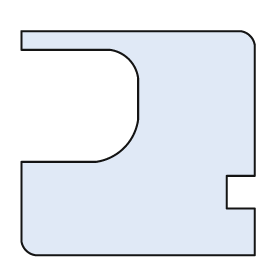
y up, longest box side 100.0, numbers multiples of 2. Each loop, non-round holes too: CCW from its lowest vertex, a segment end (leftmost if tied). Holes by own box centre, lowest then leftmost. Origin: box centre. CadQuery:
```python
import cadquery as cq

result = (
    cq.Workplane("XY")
    .moveTo(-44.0, -48.0)
    .lineTo(50.0, -48.0)
    .lineTo(50.0, -28.0)
    .lineTo(38.0, -28.0)
    .lineTo(38.0, -14.0)
    .lineTo(50.0, -14.0)
    .lineTo(50.0, 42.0)
    .threePointArc((48.0, 46.0), (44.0, 48.0))
    .lineTo(-50.0, 48.0)
    .lineTo(-50.0, 40.0)
    .lineTo(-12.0, 40.0)
    .threePointArc((-4.0, 36.0), (0.0, 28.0))
    .lineTo(0.0, 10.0)
    .threePointArc((-6.0, -2.0), (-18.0, -8.0))
    .lineTo(-50.0, -8.0)
    .lineTo(-50.0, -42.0)
    .threePointArc((-48.0, -46.0), (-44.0, -48.0))
    .close()
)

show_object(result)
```